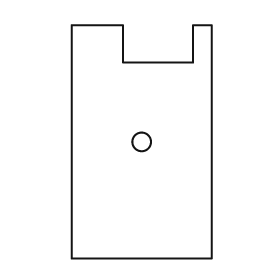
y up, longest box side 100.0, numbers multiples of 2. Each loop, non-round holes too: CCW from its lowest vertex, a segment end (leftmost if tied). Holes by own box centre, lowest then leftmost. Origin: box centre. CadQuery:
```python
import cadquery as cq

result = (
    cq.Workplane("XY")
    .moveTo(-30.0, -50.0)
    .lineTo(30.0, -50.0)
    .lineTo(30.0, 50.0)
    .lineTo(22.0, 50.0)
    .lineTo(22.0, 34.0)
    .lineTo(-8.0, 34.0)
    .lineTo(-8.0, 50.0)
    .lineTo(-30.0, 50.0)
    .close()
    .moveTo(0.0, 0.0)
    .circle(4.0)
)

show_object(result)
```